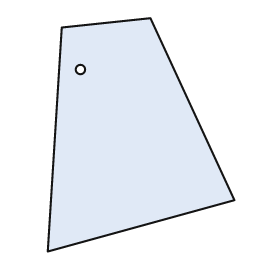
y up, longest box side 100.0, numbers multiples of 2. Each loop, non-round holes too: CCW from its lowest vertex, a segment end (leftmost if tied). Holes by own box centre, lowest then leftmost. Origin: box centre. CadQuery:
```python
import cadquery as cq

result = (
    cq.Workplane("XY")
    .moveTo(-40.0, -50.0)
    .lineTo(40.0, -28.0)
    .lineTo(4.0, 50.0)
    .lineTo(-34.0, 46.0)
    .close()
    .moveTo(-26.0, 28.0)
    .circle(2.0)
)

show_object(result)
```